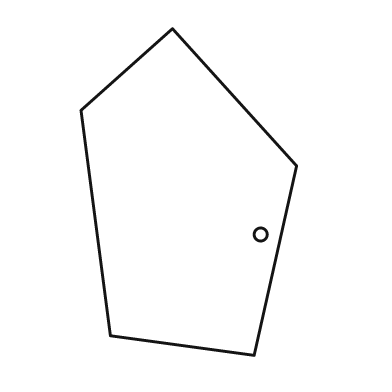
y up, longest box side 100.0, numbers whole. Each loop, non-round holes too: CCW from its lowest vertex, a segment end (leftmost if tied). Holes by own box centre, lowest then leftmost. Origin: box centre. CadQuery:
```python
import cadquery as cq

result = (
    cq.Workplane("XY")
    .moveTo(20.0, -50.0)
    .lineTo(33.0, 8.0)
    .lineTo(-5.0, 50.0)
    .lineTo(-33.0, 25.0)
    .lineTo(-24.0, -44.0)
    .close()
    .moveTo(22.0, -13.0)
    .circle(2.0)
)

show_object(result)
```